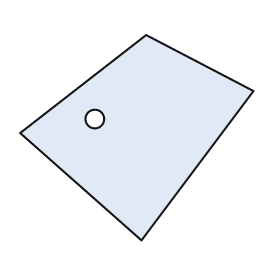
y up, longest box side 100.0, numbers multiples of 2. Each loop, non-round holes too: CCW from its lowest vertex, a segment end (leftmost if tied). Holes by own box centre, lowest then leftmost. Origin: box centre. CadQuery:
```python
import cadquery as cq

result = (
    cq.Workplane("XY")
    .moveTo(2.0, -44.0)
    .lineTo(50.0, 20.0)
    .lineTo(4.0, 44.0)
    .lineTo(-50.0, 2.0)
    .close()
    .moveTo(-18.0, 8.0)
    .circle(4.0)
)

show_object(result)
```